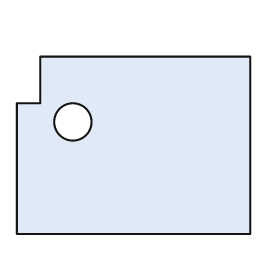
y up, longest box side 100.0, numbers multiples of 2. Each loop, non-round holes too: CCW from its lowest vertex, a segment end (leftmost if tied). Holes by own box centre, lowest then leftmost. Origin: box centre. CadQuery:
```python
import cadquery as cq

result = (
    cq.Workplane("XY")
    .moveTo(-50.0, -38.0)
    .lineTo(50.0, -38.0)
    .lineTo(50.0, 38.0)
    .lineTo(-40.0, 38.0)
    .lineTo(-40.0, 18.0)
    .lineTo(-50.0, 18.0)
    .close()
    .moveTo(-26.0, 10.0)
    .circle(8.0)
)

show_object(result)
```